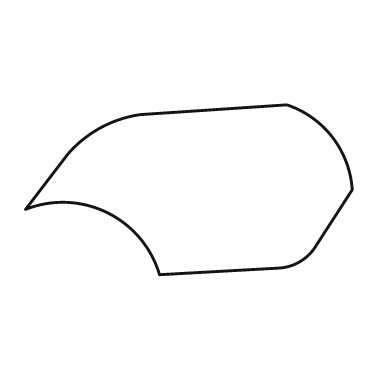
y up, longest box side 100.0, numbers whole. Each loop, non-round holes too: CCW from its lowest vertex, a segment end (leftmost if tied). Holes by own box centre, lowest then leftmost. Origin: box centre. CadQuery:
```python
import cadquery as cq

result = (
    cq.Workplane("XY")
    .moveTo(-9.0, -26.0)
    .lineTo(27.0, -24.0)
    .threePointArc((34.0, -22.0), (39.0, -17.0))
    .lineTo(50.0, 0.0)
    .threePointArc((44.0, 16.0), (30.0, 26.0))
    .lineTo(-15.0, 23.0)
    .threePointArc((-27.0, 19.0), (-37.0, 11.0))
    .lineTo(-50.0, -6.0)
    .threePointArc((-25.0, -7.0), (-9.0, -26.0))
    .close()
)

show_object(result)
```